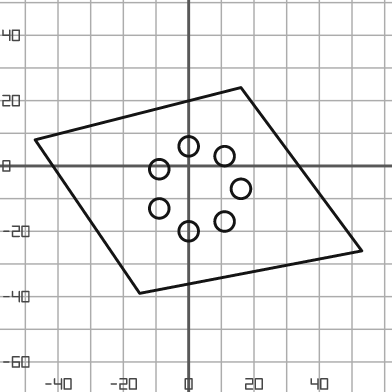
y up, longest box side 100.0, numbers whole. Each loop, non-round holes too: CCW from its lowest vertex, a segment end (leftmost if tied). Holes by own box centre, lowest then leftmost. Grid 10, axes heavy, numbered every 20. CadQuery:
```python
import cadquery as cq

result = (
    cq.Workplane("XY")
    .moveTo(-15.0, -39.0)
    .lineTo(53.0, -26.0)
    .lineTo(16.0, 24.0)
    .lineTo(-47.0, 8.0)
    .close()
    .moveTo(0.0, -20.0)
    .circle(3.0)
    .moveTo(11.0, -17.0)
    .circle(3.0)
    .moveTo(-9.0, -13.0)
    .circle(3.0)
    .moveTo(16.0, -7.0)
    .circle(3.0)
    .moveTo(-9.0, -1.0)
    .circle(3.0)
    .moveTo(11.0, 3.0)
    .circle(3.0)
    .moveTo(0.0, 6.0)
    .circle(3.0)
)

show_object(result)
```